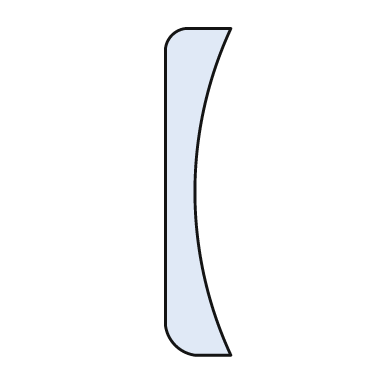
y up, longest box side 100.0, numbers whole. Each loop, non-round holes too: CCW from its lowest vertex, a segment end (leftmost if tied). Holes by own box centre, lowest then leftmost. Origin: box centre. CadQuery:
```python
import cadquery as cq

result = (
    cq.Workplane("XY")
    .moveTo(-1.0, -50.0)
    .lineTo(10.0, -50.0)
    .threePointArc((-1.0, 0.0), (10.0, 50.0))
    .lineTo(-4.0, 50.0)
    .threePointArc((-8.0, 48.0), (-10.0, 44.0))
    .lineTo(-10.0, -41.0)
    .threePointArc((-7.0, -47.0), (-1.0, -50.0))
    .close()
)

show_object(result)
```